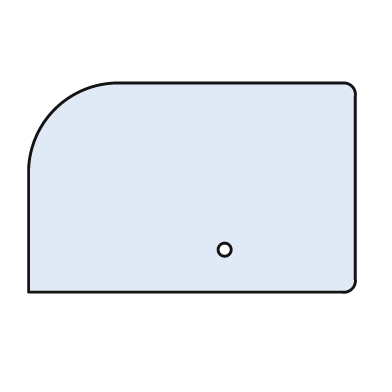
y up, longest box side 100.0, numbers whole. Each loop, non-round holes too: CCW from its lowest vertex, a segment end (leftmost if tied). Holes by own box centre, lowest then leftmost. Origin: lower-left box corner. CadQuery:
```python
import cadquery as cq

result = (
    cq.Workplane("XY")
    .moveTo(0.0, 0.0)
    .lineTo(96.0, 0.0)
    .threePointArc((99.0, 1.0), (100.0, 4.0))
    .lineTo(100.0, 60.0)
    .threePointArc((99.0, 63.0), (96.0, 64.0))
    .lineTo(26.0, 64.0)
    .threePointArc((8.0, 56.0), (0.0, 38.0))
    .close()
    .moveTo(60.0, 13.0)
    .circle(2.0)
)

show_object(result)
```